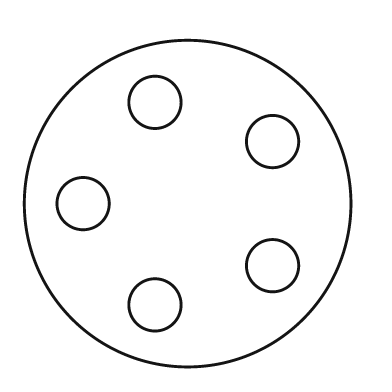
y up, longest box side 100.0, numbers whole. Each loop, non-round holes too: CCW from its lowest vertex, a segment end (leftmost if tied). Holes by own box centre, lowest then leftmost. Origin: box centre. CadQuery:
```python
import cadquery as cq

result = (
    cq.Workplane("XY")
    .moveTo(0.0, 0.0)
    .circle(50.0)
    .moveTo(-10.0, -31.0)
    .circle(8.0)
    .moveTo(26.0, -19.0)
    .circle(8.0)
    .moveTo(-32.0, 0.0)
    .circle(8.0)
    .moveTo(26.0, 19.0)
    .circle(8.0)
    .moveTo(-10.0, 31.0)
    .circle(8.0)
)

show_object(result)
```